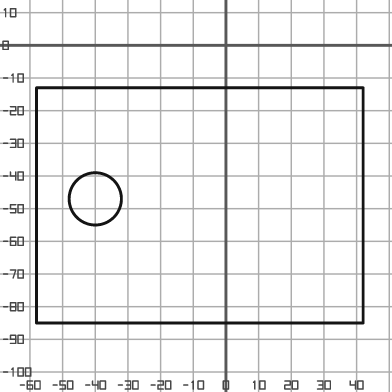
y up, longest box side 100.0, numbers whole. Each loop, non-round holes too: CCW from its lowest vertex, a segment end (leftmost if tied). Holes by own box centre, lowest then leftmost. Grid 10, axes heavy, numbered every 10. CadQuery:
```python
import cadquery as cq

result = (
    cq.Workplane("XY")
    .moveTo(-58.0, -85.0)
    .lineTo(42.0, -85.0)
    .lineTo(42.0, -13.0)
    .lineTo(-58.0, -13.0)
    .close()
    .moveTo(-40.0, -47.0)
    .circle(8.0)
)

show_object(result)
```